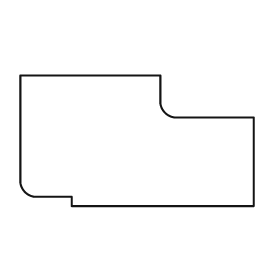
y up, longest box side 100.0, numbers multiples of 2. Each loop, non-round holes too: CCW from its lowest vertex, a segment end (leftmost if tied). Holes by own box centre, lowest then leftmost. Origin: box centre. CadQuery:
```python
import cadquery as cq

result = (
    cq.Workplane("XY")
    .moveTo(-28.0, -28.0)
    .lineTo(50.0, -28.0)
    .lineTo(50.0, 10.0)
    .lineTo(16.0, 10.0)
    .threePointArc((12.0, 12.0), (10.0, 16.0))
    .lineTo(10.0, 28.0)
    .lineTo(-50.0, 28.0)
    .lineTo(-50.0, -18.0)
    .threePointArc((-48.0, -22.0), (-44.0, -24.0))
    .lineTo(-28.0, -24.0)
    .close()
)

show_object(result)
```